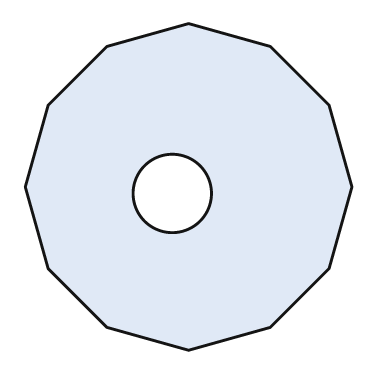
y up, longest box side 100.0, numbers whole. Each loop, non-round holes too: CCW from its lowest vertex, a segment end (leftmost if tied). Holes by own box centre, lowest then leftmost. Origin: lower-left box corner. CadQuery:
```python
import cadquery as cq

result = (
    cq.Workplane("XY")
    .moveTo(50.0, 0.0)
    .lineTo(75.0, 7.0)
    .lineTo(93.0, 25.0)
    .lineTo(100.0, 50.0)
    .lineTo(93.0, 75.0)
    .lineTo(75.0, 93.0)
    .lineTo(50.0, 100.0)
    .lineTo(25.0, 93.0)
    .lineTo(7.0, 75.0)
    .lineTo(0.0, 50.0)
    .lineTo(7.0, 25.0)
    .lineTo(25.0, 7.0)
    .close()
    .moveTo(45.0, 48.0)
    .circle(12.0)
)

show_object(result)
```